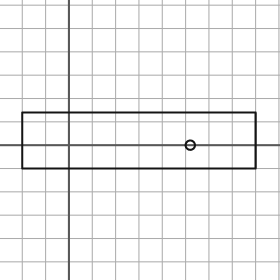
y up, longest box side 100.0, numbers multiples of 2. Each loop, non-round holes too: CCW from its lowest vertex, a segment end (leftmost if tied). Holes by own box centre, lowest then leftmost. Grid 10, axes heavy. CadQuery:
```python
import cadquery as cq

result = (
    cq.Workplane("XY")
    .moveTo(-20.0, -10.0)
    .lineTo(80.0, -10.0)
    .lineTo(80.0, 14.0)
    .lineTo(-20.0, 14.0)
    .close()
    .moveTo(52.0, 0.0)
    .circle(2.0)
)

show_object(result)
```